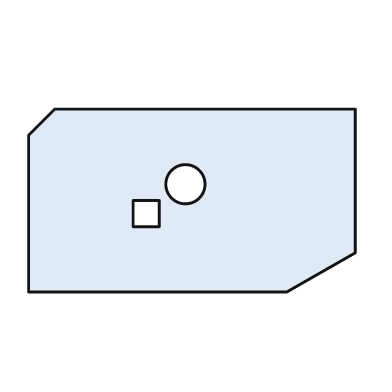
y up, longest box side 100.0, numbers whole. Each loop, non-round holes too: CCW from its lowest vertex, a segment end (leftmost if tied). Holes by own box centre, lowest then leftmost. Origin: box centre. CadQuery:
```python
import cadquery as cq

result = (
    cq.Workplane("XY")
    .moveTo(-50.0, -28.0)
    .lineTo(29.0, -28.0)
    .lineTo(50.0, -16.0)
    .lineTo(50.0, 28.0)
    .lineTo(-42.0, 28.0)
    .lineTo(-50.0, 20.0)
    .close()
    .moveTo(-18.0, -8.0)
    .lineTo(-10.0, -8.0)
    .lineTo(-10.0, 0.0)
    .lineTo(-18.0, 0.0)
    .close()
    .moveTo(-2.0, 5.0)
    .circle(6.0)
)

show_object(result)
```